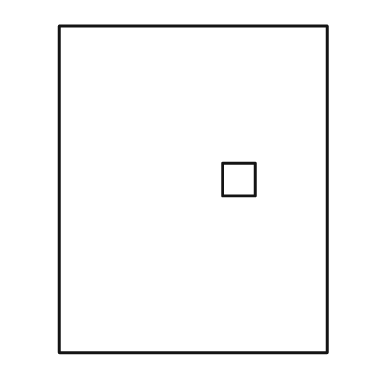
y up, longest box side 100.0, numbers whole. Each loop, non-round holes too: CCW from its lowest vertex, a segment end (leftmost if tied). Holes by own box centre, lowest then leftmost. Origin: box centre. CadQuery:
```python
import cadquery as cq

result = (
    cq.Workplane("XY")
    .moveTo(-41.0, -50.0)
    .lineTo(41.0, -50.0)
    .lineTo(41.0, 50.0)
    .lineTo(-41.0, 50.0)
    .close()
    .moveTo(9.0, -2.0)
    .lineTo(19.0, -2.0)
    .lineTo(19.0, 8.0)
    .lineTo(9.0, 8.0)
    .close()
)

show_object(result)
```